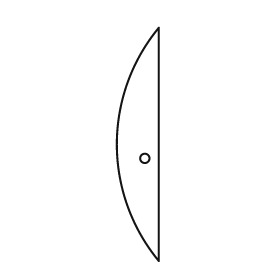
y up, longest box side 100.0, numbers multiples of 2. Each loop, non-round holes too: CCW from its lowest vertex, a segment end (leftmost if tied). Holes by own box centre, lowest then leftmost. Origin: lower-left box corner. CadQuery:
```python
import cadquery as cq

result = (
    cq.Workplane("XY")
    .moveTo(18.0, 0.0)
    .lineTo(18.0, 100.0)
    .threePointArc((0.0, 50.0), (18.0, 0.0))
    .close()
    .moveTo(12.0, 44.0)
    .circle(2.0)
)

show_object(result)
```